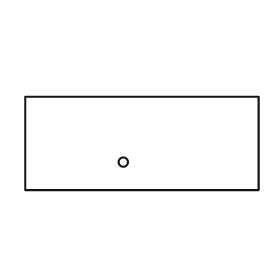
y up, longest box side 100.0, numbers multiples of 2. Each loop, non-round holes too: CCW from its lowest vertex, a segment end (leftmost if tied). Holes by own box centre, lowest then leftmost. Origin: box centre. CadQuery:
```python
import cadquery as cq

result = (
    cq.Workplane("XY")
    .moveTo(-50.0, -20.0)
    .lineTo(50.0, -20.0)
    .lineTo(50.0, 20.0)
    .lineTo(-50.0, 20.0)
    .close()
    .moveTo(-8.0, -8.0)
    .circle(2.0)
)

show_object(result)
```